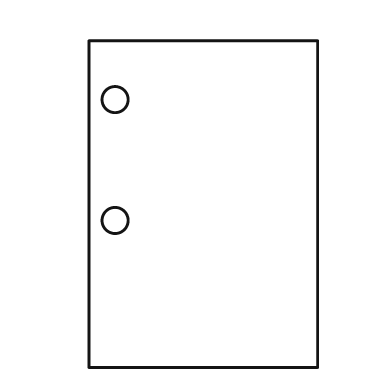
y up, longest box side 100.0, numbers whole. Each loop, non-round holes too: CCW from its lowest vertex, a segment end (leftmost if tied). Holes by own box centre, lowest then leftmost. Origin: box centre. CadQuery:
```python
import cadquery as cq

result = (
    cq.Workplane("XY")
    .moveTo(-35.0, -50.0)
    .lineTo(35.0, -50.0)
    .lineTo(35.0, 50.0)
    .lineTo(-35.0, 50.0)
    .close()
    .moveTo(-27.0, -5.0)
    .circle(4.0)
    .moveTo(-27.0, 32.0)
    .circle(4.0)
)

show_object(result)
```